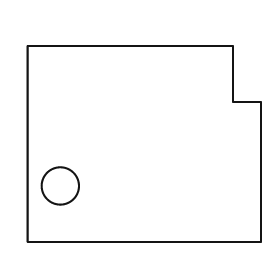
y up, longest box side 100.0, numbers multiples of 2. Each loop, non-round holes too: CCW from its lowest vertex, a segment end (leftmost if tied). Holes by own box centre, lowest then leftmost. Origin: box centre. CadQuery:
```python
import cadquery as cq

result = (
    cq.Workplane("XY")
    .moveTo(-50.0, -42.0)
    .lineTo(50.0, -42.0)
    .lineTo(50.0, 18.0)
    .lineTo(38.0, 18.0)
    .lineTo(38.0, 42.0)
    .lineTo(-50.0, 42.0)
    .close()
    .moveTo(-36.0, -18.0)
    .circle(8.0)
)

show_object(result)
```